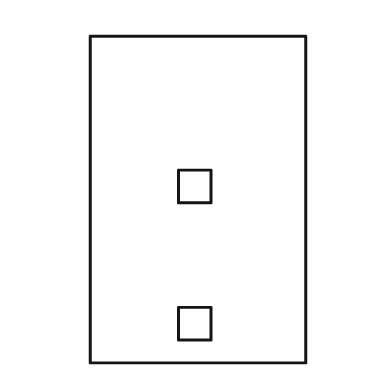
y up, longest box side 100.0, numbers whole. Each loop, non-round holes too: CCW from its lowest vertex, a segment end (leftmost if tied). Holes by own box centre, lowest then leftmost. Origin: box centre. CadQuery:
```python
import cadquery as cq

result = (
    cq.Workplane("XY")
    .moveTo(-33.0, -50.0)
    .lineTo(33.0, -50.0)
    .lineTo(33.0, 50.0)
    .lineTo(-33.0, 50.0)
    .close()
    .moveTo(-6.0, -43.0)
    .lineTo(4.0, -43.0)
    .lineTo(4.0, -33.0)
    .lineTo(-6.0, -33.0)
    .close()
    .moveTo(-6.0, -1.0)
    .lineTo(4.0, -1.0)
    .lineTo(4.0, 9.0)
    .lineTo(-6.0, 9.0)
    .close()
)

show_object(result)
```